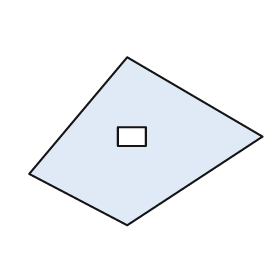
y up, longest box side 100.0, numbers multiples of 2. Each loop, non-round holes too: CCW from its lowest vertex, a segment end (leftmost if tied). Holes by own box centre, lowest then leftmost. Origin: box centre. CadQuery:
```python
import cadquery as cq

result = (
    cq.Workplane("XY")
    .moveTo(-8.0, -36.0)
    .lineTo(50.0, 2.0)
    .lineTo(-8.0, 36.0)
    .lineTo(-50.0, -14.0)
    .close()
    .moveTo(-12.0, -2.0)
    .lineTo(0.0, -2.0)
    .lineTo(0.0, 6.0)
    .lineTo(-12.0, 6.0)
    .close()
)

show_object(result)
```